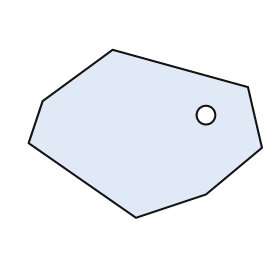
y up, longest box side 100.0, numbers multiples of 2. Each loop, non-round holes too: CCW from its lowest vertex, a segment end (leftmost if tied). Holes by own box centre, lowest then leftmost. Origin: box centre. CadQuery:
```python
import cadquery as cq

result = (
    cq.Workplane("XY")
    .moveTo(-4.0, -36.0)
    .lineTo(26.0, -26.0)
    .lineTo(50.0, -6.0)
    .lineTo(44.0, 20.0)
    .lineTo(-14.0, 36.0)
    .lineTo(-44.0, 14.0)
    .lineTo(-50.0, -4.0)
    .close()
    .moveTo(26.0, 8.0)
    .circle(4.0)
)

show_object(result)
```